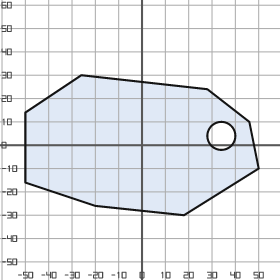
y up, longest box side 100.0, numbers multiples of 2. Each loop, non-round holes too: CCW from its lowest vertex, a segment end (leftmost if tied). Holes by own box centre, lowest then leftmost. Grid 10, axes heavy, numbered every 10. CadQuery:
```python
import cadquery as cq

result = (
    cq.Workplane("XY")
    .moveTo(18.0, -30.0)
    .lineTo(50.0, -10.0)
    .lineTo(46.0, 10.0)
    .lineTo(28.0, 24.0)
    .lineTo(-26.0, 30.0)
    .lineTo(-50.0, 14.0)
    .lineTo(-50.0, -16.0)
    .lineTo(-20.0, -26.0)
    .close()
    .moveTo(34.0, 4.0)
    .circle(6.0)
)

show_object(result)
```